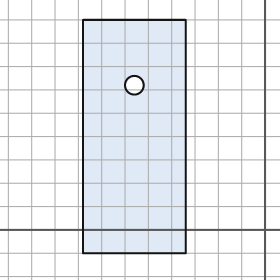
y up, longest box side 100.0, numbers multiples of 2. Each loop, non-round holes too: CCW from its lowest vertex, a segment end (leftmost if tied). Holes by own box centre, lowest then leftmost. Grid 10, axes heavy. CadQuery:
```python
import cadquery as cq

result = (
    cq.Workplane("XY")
    .moveTo(-78.0, -10.0)
    .lineTo(-34.0, -10.0)
    .lineTo(-34.0, 90.0)
    .lineTo(-78.0, 90.0)
    .close()
    .moveTo(-56.0, 62.0)
    .circle(4.0)
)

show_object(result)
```